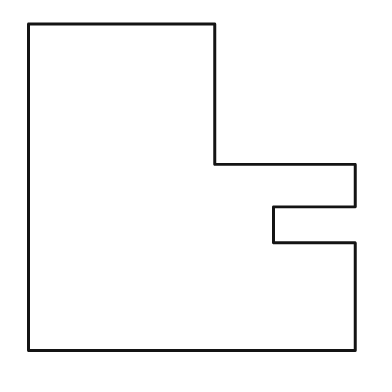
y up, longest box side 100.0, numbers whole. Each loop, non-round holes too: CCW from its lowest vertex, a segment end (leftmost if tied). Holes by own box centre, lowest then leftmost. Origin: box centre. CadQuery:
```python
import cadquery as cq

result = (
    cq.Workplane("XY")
    .moveTo(-50.0, -50.0)
    .lineTo(50.0, -50.0)
    .lineTo(50.0, -17.0)
    .lineTo(25.0, -17.0)
    .lineTo(25.0, -6.0)
    .lineTo(50.0, -6.0)
    .lineTo(50.0, 7.0)
    .lineTo(7.0, 7.0)
    .lineTo(7.0, 50.0)
    .lineTo(-50.0, 50.0)
    .close()
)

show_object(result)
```